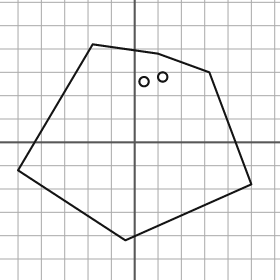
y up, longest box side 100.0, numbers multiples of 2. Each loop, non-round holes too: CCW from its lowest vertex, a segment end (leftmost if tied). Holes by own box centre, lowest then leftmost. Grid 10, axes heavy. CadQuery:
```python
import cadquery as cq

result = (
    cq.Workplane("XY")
    .moveTo(-4.0, -42.0)
    .lineTo(50.0, -18.0)
    .lineTo(32.0, 30.0)
    .lineTo(10.0, 38.0)
    .lineTo(-18.0, 42.0)
    .lineTo(-50.0, -12.0)
    .close()
    .moveTo(4.0, 26.0)
    .circle(2.0)
    .moveTo(12.0, 28.0)
    .circle(2.0)
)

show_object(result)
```